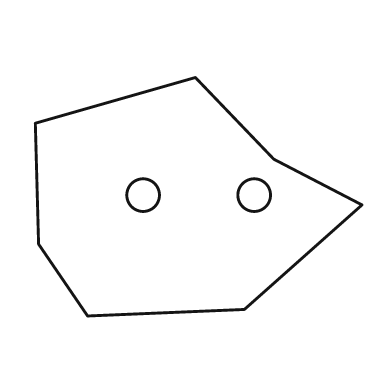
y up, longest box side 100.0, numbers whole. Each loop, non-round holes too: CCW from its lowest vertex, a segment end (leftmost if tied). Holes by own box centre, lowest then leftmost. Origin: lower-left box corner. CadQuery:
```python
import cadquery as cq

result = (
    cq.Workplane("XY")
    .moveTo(16.0, 0.0)
    .lineTo(64.0, 2.0)
    .lineTo(100.0, 34.0)
    .lineTo(73.0, 48.0)
    .lineTo(49.0, 73.0)
    .lineTo(0.0, 59.0)
    .lineTo(1.0, 22.0)
    .close()
    .moveTo(33.0, 37.0)
    .circle(5.0)
    .moveTo(67.0, 37.0)
    .circle(5.0)
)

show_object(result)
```